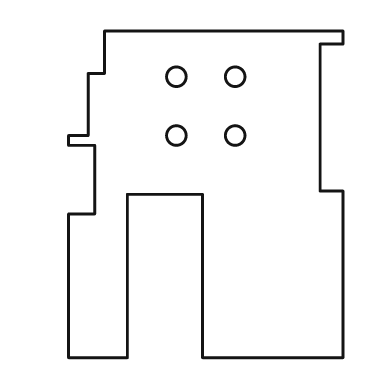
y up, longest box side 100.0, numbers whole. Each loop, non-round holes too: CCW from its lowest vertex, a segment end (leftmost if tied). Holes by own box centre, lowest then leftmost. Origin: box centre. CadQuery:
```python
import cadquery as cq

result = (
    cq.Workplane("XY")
    .moveTo(-42.0, -50.0)
    .lineTo(-24.0, -50.0)
    .lineTo(-24.0, 0.0)
    .lineTo(-1.0, 0.0)
    .lineTo(-1.0, -50.0)
    .lineTo(42.0, -50.0)
    .lineTo(42.0, 1.0)
    .lineTo(35.0, 1.0)
    .lineTo(35.0, 46.0)
    .lineTo(42.0, 46.0)
    .lineTo(42.0, 50.0)
    .lineTo(-31.0, 50.0)
    .lineTo(-31.0, 37.0)
    .lineTo(-36.0, 37.0)
    .lineTo(-36.0, 18.0)
    .lineTo(-42.0, 18.0)
    .lineTo(-42.0, 15.0)
    .lineTo(-34.0, 15.0)
    .lineTo(-34.0, -6.0)
    .lineTo(-42.0, -6.0)
    .close()
    .moveTo(-9.0, 18.0)
    .circle(3.0)
    .moveTo(9.0, 18.0)
    .circle(3.0)
    .moveTo(-9.0, 36.0)
    .circle(3.0)
    .moveTo(9.0, 36.0)
    .circle(3.0)
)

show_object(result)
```